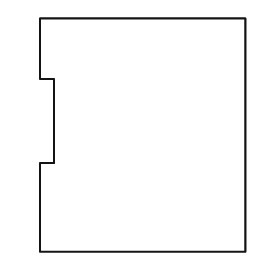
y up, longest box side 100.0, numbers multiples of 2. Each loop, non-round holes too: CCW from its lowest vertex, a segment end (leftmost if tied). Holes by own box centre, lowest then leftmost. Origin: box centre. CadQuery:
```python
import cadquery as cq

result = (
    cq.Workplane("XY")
    .moveTo(-44.0, -50.0)
    .lineTo(44.0, -50.0)
    .lineTo(44.0, 50.0)
    .lineTo(-44.0, 50.0)
    .lineTo(-44.0, 24.0)
    .lineTo(-38.0, 24.0)
    .lineTo(-38.0, -12.0)
    .lineTo(-44.0, -12.0)
    .close()
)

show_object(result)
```